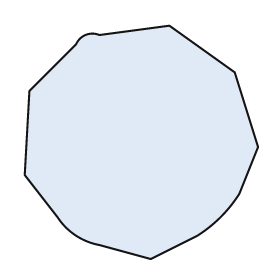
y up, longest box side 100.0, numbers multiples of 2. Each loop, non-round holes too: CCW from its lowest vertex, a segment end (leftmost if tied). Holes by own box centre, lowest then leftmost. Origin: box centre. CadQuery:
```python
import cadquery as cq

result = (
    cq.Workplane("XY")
    .moveTo(4.0, -50.0)
    .lineTo(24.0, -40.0)
    .threePointArc((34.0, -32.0), (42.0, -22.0))
    .lineTo(50.0, -2.0)
    .lineTo(40.0, 30.0)
    .lineTo(12.0, 50.0)
    .lineTo(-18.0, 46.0)
    .threePointArc((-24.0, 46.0), (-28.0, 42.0))
    .lineTo(-48.0, 22.0)
    .lineTo(-50.0, -14.0)
    .lineTo(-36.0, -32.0)
    .threePointArc((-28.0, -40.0), (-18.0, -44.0))
    .close()
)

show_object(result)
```